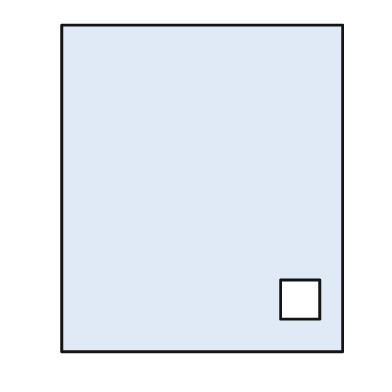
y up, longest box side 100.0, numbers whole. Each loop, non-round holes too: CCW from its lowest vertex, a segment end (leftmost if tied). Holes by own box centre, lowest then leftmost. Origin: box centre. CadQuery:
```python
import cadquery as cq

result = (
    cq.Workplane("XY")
    .moveTo(-43.0, -50.0)
    .lineTo(43.0, -50.0)
    .lineTo(43.0, 50.0)
    .lineTo(-43.0, 50.0)
    .close()
    .moveTo(24.0, -40.0)
    .lineTo(36.0, -40.0)
    .lineTo(36.0, -28.0)
    .lineTo(24.0, -28.0)
    .close()
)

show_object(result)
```